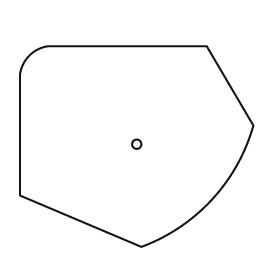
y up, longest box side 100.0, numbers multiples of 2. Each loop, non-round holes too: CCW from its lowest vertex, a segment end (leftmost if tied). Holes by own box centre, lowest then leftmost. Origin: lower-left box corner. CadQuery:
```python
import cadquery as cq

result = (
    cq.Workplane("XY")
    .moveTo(52.0, 0.0)
    .threePointArc((82.0, 20.0), (100.0, 52.0))
    .lineTo(80.0, 86.0)
    .lineTo(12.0, 86.0)
    .threePointArc((4.0, 82.0), (0.0, 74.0))
    .lineTo(0.0, 22.0)
    .close()
    .moveTo(50.0, 44.0)
    .circle(2.0)
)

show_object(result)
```